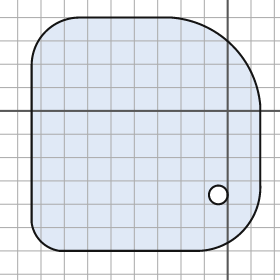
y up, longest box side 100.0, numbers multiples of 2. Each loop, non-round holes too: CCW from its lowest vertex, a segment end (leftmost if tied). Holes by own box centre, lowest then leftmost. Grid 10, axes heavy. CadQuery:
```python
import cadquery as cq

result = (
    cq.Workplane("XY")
    .moveTo(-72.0, -60.0)
    .lineTo(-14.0, -60.0)
    .threePointArc((6.0, -52.0), (14.0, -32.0))
    .lineTo(14.0, 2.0)
    .threePointArc((2.0, 28.0), (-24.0, 40.0))
    .lineTo(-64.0, 40.0)
    .threePointArc((-78.0, 34.0), (-84.0, 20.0))
    .lineTo(-84.0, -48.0)
    .threePointArc((-80.0, -56.0), (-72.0, -60.0))
    .close()
    .moveTo(-4.0, -36.0)
    .circle(4.0)
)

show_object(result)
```